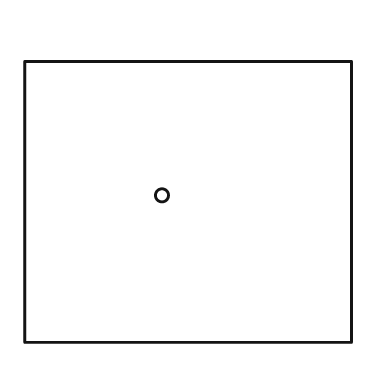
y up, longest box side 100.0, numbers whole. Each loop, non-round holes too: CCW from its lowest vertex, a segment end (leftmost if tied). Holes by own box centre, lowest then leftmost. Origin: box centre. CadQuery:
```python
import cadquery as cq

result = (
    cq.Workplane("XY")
    .moveTo(-50.0, -43.0)
    .lineTo(50.0, -43.0)
    .lineTo(50.0, 43.0)
    .lineTo(-50.0, 43.0)
    .close()
    .moveTo(-8.0, 2.0)
    .circle(2.0)
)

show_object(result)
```